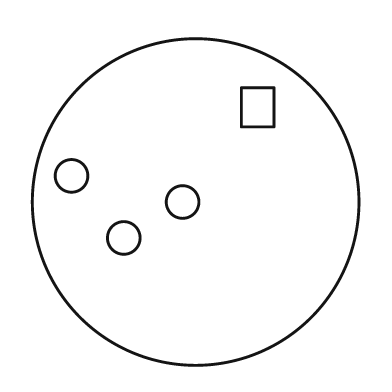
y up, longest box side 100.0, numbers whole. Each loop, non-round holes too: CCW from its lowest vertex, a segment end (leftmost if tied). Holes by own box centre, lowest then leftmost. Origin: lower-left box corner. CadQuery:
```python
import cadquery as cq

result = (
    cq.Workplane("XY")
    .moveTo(50.0, 50.0)
    .circle(50.0)
    .moveTo(28.0, 39.0)
    .circle(5.0)
    .moveTo(46.0, 50.0)
    .circle(5.0)
    .moveTo(12.0, 58.0)
    .circle(5.0)
    .moveTo(64.0, 73.0)
    .lineTo(74.0, 73.0)
    .lineTo(74.0, 85.0)
    .lineTo(64.0, 85.0)
    .close()
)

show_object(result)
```